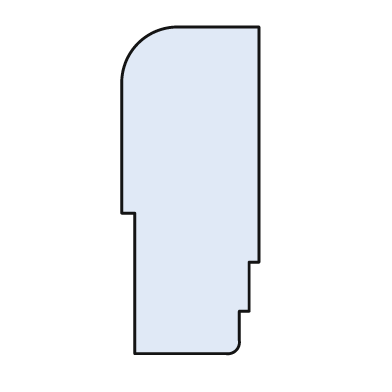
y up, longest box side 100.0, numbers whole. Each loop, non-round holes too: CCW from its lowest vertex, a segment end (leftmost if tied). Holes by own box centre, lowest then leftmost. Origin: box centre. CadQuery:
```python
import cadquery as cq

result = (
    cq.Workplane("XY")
    .moveTo(-17.0, -50.0)
    .lineTo(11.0, -50.0)
    .threePointArc((14.0, -49.0), (15.0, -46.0))
    .lineTo(15.0, -37.0)
    .lineTo(18.0, -37.0)
    .lineTo(18.0, -22.0)
    .lineTo(21.0, -22.0)
    .lineTo(21.0, 50.0)
    .lineTo(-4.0, 50.0)
    .threePointArc((-16.0, 45.0), (-21.0, 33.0))
    .lineTo(-21.0, -7.0)
    .lineTo(-17.0, -7.0)
    .close()
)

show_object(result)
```